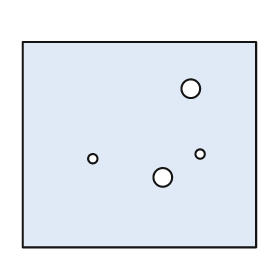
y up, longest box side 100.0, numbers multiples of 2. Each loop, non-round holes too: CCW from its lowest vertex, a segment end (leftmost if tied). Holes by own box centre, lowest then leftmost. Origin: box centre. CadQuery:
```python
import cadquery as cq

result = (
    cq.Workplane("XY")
    .moveTo(-50.0, -44.0)
    .lineTo(50.0, -44.0)
    .lineTo(50.0, 44.0)
    .lineTo(-50.0, 44.0)
    .close()
    .moveTo(10.0, -14.0)
    .circle(4.0)
    .moveTo(-20.0, -6.0)
    .circle(2.0)
    .moveTo(26.0, -4.0)
    .circle(2.0)
    .moveTo(22.0, 24.0)
    .circle(4.0)
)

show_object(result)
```